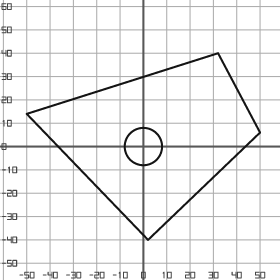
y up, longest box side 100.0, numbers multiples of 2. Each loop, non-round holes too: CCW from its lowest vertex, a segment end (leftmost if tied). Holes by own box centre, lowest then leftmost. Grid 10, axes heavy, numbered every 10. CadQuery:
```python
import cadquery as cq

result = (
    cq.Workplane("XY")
    .moveTo(2.0, -40.0)
    .lineTo(50.0, 6.0)
    .lineTo(32.0, 40.0)
    .lineTo(-50.0, 14.0)
    .close()
    .moveTo(0.0, 0.0)
    .circle(8.0)
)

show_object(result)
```